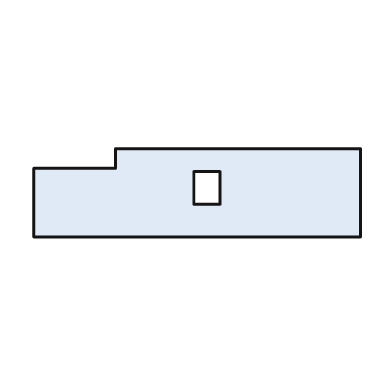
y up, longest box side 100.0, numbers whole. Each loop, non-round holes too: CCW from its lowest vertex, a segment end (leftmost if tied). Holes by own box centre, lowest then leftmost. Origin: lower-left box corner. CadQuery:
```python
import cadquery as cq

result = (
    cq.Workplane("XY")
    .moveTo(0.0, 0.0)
    .lineTo(100.0, 0.0)
    .lineTo(100.0, 27.0)
    .lineTo(25.0, 27.0)
    .lineTo(25.0, 21.0)
    .lineTo(0.0, 21.0)
    .close()
    .moveTo(49.0, 10.0)
    .lineTo(57.0, 10.0)
    .lineTo(57.0, 20.0)
    .lineTo(49.0, 20.0)
    .close()
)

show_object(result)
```